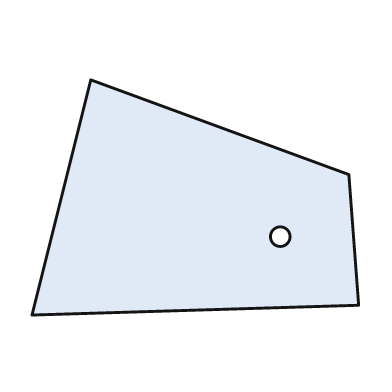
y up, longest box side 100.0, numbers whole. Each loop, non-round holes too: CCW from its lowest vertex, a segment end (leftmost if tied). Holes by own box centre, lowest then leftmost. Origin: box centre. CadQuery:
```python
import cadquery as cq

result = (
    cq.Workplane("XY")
    .moveTo(-50.0, -36.0)
    .lineTo(50.0, -33.0)
    .lineTo(47.0, 7.0)
    .lineTo(-32.0, 36.0)
    .close()
    .moveTo(26.0, -12.0)
    .circle(3.0)
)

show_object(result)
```